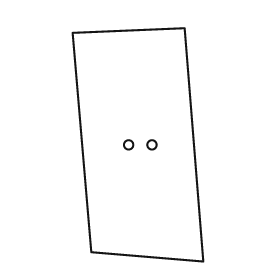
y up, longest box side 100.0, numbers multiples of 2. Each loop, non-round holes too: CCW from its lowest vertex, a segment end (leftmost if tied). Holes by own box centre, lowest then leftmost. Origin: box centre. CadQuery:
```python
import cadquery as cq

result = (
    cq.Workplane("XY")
    .moveTo(28.0, -50.0)
    .lineTo(20.0, 50.0)
    .lineTo(-28.0, 48.0)
    .lineTo(-20.0, -46.0)
    .close()
    .moveTo(-4.0, 0.0)
    .circle(2.0)
    .moveTo(6.0, 0.0)
    .circle(2.0)
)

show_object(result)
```